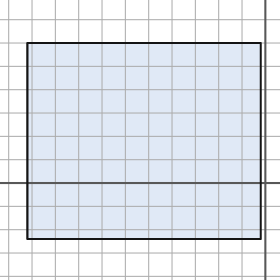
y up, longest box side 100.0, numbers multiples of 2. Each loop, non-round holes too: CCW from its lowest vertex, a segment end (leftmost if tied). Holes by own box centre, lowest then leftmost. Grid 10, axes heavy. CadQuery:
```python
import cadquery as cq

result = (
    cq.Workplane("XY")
    .moveTo(-102.0, -24.0)
    .lineTo(-2.0, -24.0)
    .lineTo(-2.0, 60.0)
    .lineTo(-102.0, 60.0)
    .close()
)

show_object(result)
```